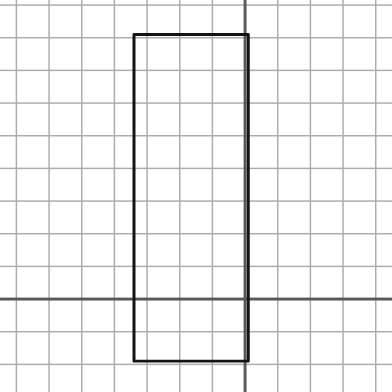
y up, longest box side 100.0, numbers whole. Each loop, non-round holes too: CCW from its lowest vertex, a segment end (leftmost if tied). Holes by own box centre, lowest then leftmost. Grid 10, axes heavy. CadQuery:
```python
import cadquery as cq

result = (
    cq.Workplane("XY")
    .moveTo(-34.0, -19.0)
    .lineTo(1.0, -19.0)
    .lineTo(1.0, 81.0)
    .lineTo(-34.0, 81.0)
    .close()
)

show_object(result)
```